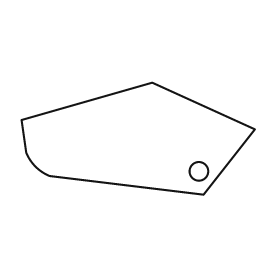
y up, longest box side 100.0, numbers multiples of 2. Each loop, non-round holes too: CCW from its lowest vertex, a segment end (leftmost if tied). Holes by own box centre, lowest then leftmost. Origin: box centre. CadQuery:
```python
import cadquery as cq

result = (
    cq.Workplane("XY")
    .moveTo(28.0, -24.0)
    .lineTo(50.0, 4.0)
    .lineTo(6.0, 24.0)
    .lineTo(-50.0, 8.0)
    .lineTo(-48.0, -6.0)
    .threePointArc((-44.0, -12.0), (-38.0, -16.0))
    .close()
    .moveTo(26.0, -14.0)
    .circle(4.0)
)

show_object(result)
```